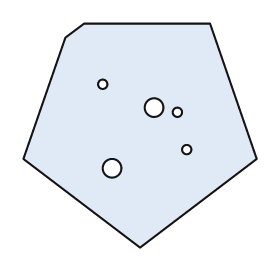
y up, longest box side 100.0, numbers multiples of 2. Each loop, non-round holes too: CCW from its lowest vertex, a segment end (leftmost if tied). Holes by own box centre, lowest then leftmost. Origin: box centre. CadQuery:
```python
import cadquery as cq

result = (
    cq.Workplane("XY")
    .moveTo(0.0, -48.0)
    .lineTo(50.0, -10.0)
    .lineTo(30.0, 48.0)
    .lineTo(-24.0, 48.0)
    .lineTo(-32.0, 42.0)
    .lineTo(-50.0, -10.0)
    .close()
    .moveTo(-12.0, -14.0)
    .circle(4.0)
    .moveTo(20.0, -6.0)
    .circle(2.0)
    .moveTo(16.0, 10.0)
    .circle(2.0)
    .moveTo(6.0, 12.0)
    .circle(4.0)
    .moveTo(-16.0, 22.0)
    .circle(2.0)
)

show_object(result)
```